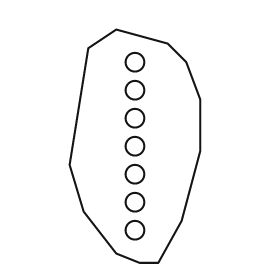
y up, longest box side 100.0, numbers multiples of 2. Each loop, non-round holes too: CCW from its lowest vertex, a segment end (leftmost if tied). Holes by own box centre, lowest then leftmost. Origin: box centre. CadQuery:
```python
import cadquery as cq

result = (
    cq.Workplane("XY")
    .moveTo(2.0, -50.0)
    .lineTo(10.0, -50.0)
    .lineTo(20.0, -32.0)
    .lineTo(28.0, -2.0)
    .lineTo(28.0, 20.0)
    .lineTo(22.0, 36.0)
    .lineTo(14.0, 44.0)
    .lineTo(-8.0, 50.0)
    .lineTo(-20.0, 42.0)
    .lineTo(-28.0, -8.0)
    .lineTo(-22.0, -28.0)
    .lineTo(-8.0, -46.0)
    .close()
    .moveTo(0.0, -36.0)
    .circle(4.0)
    .moveTo(0.0, -24.0)
    .circle(4.0)
    .moveTo(0.0, -12.0)
    .circle(4.0)
    .moveTo(0.0, 0.0)
    .circle(4.0)
    .moveTo(0.0, 12.0)
    .circle(4.0)
    .moveTo(0.0, 24.0)
    .circle(4.0)
    .moveTo(0.0, 36.0)
    .circle(4.0)
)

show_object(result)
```